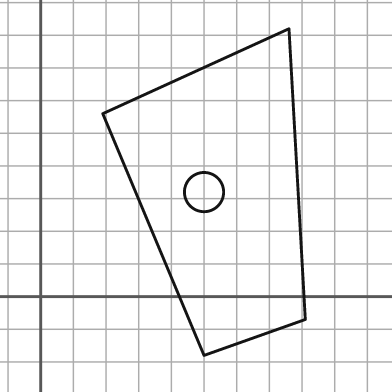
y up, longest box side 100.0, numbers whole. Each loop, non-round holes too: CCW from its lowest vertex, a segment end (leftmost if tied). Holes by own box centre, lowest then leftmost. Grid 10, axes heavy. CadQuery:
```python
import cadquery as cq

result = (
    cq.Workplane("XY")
    .moveTo(50.0, -18.0)
    .lineTo(81.0, -7.0)
    .lineTo(76.0, 82.0)
    .lineTo(19.0, 56.0)
    .close()
    .moveTo(50.0, 32.0)
    .circle(6.0)
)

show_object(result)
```